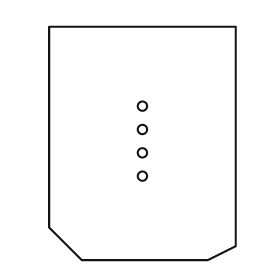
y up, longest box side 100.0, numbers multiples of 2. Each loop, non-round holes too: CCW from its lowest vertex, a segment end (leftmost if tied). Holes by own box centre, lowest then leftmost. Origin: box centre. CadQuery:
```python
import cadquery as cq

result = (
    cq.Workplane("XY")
    .moveTo(-26.0, -50.0)
    .lineTo(28.0, -50.0)
    .lineTo(40.0, -44.0)
    .lineTo(40.0, 50.0)
    .lineTo(-40.0, 50.0)
    .lineTo(-40.0, -36.0)
    .close()
    .moveTo(0.0, -14.0)
    .circle(2.0)
    .moveTo(0.0, -4.0)
    .circle(2.0)
    .moveTo(0.0, 6.0)
    .circle(2.0)
    .moveTo(0.0, 16.0)
    .circle(2.0)
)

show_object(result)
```